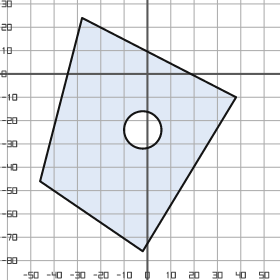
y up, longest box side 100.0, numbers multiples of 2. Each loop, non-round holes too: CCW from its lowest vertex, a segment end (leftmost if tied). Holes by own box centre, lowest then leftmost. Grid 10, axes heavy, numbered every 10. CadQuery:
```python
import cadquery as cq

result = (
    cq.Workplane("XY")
    .moveTo(-2.0, -76.0)
    .lineTo(38.0, -10.0)
    .lineTo(-28.0, 24.0)
    .lineTo(-46.0, -46.0)
    .close()
    .moveTo(-2.0, -24.0)
    .circle(8.0)
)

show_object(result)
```